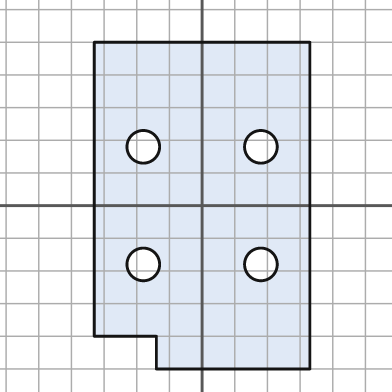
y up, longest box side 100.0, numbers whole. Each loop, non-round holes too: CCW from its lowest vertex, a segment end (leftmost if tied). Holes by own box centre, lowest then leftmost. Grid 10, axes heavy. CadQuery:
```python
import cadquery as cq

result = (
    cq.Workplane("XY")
    .moveTo(-14.0, -50.0)
    .lineTo(33.0, -50.0)
    .lineTo(33.0, 50.0)
    .lineTo(-33.0, 50.0)
    .lineTo(-33.0, -40.0)
    .lineTo(-14.0, -40.0)
    .close()
    .moveTo(-18.0, -18.0)
    .circle(5.0)
    .moveTo(18.0, -18.0)
    .circle(5.0)
    .moveTo(-18.0, 18.0)
    .circle(5.0)
    .moveTo(18.0, 18.0)
    .circle(5.0)
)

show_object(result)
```